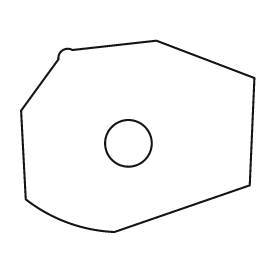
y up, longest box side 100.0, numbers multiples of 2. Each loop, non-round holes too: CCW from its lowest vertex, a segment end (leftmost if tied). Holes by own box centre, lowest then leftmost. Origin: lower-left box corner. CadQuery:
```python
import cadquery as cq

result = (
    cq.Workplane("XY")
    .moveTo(40.0, 0.0)
    .lineTo(98.0, 20.0)
    .lineTo(100.0, 66.0)
    .lineTo(58.0, 82.0)
    .lineTo(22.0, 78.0)
    .threePointArc((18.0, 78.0), (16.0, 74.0))
    .lineTo(0.0, 52.0)
    .lineTo(2.0, 14.0)
    .threePointArc((20.0, 4.0), (40.0, 0.0))
    .close()
    .moveTo(46.0, 38.0)
    .circle(10.0)
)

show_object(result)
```